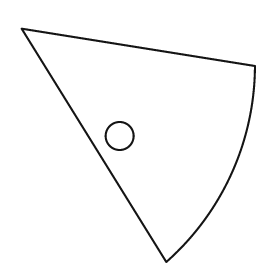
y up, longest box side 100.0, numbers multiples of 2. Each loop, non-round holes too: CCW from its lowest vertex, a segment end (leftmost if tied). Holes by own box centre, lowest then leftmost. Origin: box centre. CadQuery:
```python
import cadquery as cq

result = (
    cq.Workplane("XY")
    .moveTo(12.0, -50.0)
    .threePointArc((40.0, -12.0), (50.0, 34.0))
    .lineTo(-50.0, 50.0)
    .close()
    .moveTo(-8.0, 4.0)
    .circle(6.0)
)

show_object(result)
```